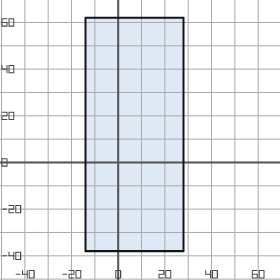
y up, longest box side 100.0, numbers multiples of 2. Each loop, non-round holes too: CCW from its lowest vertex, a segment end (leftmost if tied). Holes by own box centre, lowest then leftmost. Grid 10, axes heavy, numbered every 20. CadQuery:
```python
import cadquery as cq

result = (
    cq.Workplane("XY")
    .moveTo(-14.0, -38.0)
    .lineTo(28.0, -38.0)
    .lineTo(28.0, 62.0)
    .lineTo(-14.0, 62.0)
    .close()
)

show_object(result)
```